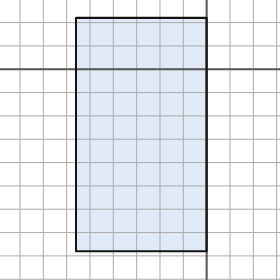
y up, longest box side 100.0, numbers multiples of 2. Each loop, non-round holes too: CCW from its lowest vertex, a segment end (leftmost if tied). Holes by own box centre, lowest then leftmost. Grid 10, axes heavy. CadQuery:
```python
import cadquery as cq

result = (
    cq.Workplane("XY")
    .moveTo(-56.0, -78.0)
    .lineTo(0.0, -78.0)
    .lineTo(0.0, 22.0)
    .lineTo(-56.0, 22.0)
    .close()
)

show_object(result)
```